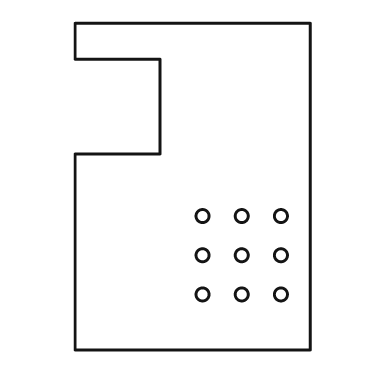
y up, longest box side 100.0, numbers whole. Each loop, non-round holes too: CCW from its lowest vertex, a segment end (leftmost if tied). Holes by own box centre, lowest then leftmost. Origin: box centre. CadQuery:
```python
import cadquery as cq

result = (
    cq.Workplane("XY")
    .moveTo(-36.0, -50.0)
    .lineTo(36.0, -50.0)
    .lineTo(36.0, 50.0)
    .lineTo(-36.0, 50.0)
    .lineTo(-36.0, 39.0)
    .lineTo(-10.0, 39.0)
    .lineTo(-10.0, 10.0)
    .lineTo(-36.0, 10.0)
    .close()
    .moveTo(3.0, -33.0)
    .circle(2.0)
    .moveTo(15.0, -33.0)
    .circle(2.0)
    .moveTo(27.0, -33.0)
    .circle(2.0)
    .moveTo(3.0, -21.0)
    .circle(2.0)
    .moveTo(15.0, -21.0)
    .circle(2.0)
    .moveTo(27.0, -21.0)
    .circle(2.0)
    .moveTo(3.0, -9.0)
    .circle(2.0)
    .moveTo(15.0, -9.0)
    .circle(2.0)
    .moveTo(27.0, -9.0)
    .circle(2.0)
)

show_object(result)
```